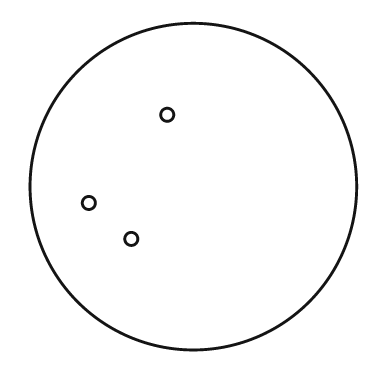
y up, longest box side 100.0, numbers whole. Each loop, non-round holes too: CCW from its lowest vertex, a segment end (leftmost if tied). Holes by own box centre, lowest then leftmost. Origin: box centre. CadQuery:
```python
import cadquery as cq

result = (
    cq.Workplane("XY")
    .moveTo(0.0, 0.0)
    .circle(50.0)
    .moveTo(-19.0, -16.0)
    .circle(2.0)
    .moveTo(-32.0, -5.0)
    .circle(2.0)
    .moveTo(-8.0, 22.0)
    .circle(2.0)
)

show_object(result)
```